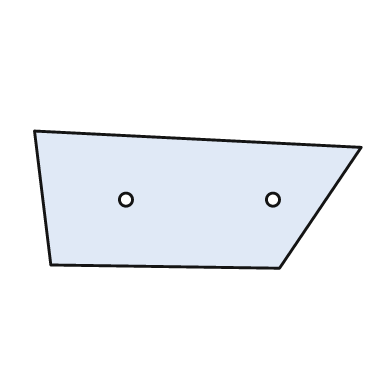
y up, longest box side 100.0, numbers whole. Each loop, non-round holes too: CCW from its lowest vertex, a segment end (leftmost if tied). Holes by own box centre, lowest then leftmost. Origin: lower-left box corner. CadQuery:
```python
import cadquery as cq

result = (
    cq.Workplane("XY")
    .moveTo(75.0, 0.0)
    .lineTo(100.0, 37.0)
    .lineTo(0.0, 42.0)
    .lineTo(5.0, 1.0)
    .close()
    .moveTo(28.0, 21.0)
    .circle(2.0)
    .moveTo(73.0, 21.0)
    .circle(2.0)
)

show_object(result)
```